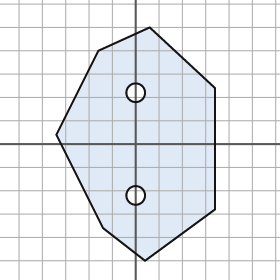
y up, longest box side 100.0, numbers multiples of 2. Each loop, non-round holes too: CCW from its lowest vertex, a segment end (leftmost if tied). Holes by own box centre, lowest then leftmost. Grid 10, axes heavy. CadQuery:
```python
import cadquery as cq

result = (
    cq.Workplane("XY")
    .moveTo(4.0, -50.0)
    .lineTo(34.0, -28.0)
    .lineTo(34.0, 24.0)
    .lineTo(6.0, 50.0)
    .lineTo(-16.0, 40.0)
    .lineTo(-34.0, 4.0)
    .lineTo(-14.0, -36.0)
    .close()
    .moveTo(0.0, -22.0)
    .circle(4.0)
    .moveTo(0.0, 22.0)
    .circle(4.0)
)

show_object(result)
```